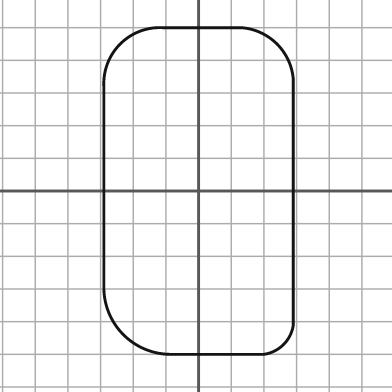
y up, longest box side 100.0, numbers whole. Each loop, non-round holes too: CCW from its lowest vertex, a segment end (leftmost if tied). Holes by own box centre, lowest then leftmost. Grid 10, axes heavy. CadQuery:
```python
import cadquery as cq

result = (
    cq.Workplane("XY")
    .moveTo(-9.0, -50.0)
    .lineTo(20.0, -50.0)
    .threePointArc((26.0, -47.0), (29.0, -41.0))
    .lineTo(29.0, 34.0)
    .threePointArc((24.0, 45.0), (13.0, 50.0))
    .lineTo(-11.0, 50.0)
    .threePointArc((-24.0, 45.0), (-29.0, 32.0))
    .lineTo(-29.0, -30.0)
    .threePointArc((-23.0, -44.0), (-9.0, -50.0))
    .close()
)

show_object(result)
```